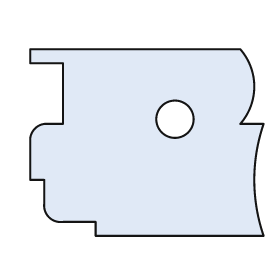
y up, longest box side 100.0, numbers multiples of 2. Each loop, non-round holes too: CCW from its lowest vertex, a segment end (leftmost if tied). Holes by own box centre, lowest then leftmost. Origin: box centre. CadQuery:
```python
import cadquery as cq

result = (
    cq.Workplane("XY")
    .moveTo(-22.0, -40.0)
    .lineTo(50.0, -40.0)
    .threePointArc((46.0, -16.0), (50.0, 8.0))
    .lineTo(40.0, 8.0)
    .threePointArc((46.0, 24.0), (40.0, 40.0))
    .lineTo(-50.0, 40.0)
    .lineTo(-50.0, 34.0)
    .lineTo(-36.0, 34.0)
    .lineTo(-36.0, 8.0)
    .lineTo(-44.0, 8.0)
    .threePointArc((-48.0, 6.0), (-50.0, 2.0))
    .lineTo(-50.0, -16.0)
    .lineTo(-44.0, -16.0)
    .lineTo(-44.0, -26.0)
    .threePointArc((-42.0, -32.0), (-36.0, -34.0))
    .lineTo(-22.0, -34.0)
    .close()
    .moveTo(12.0, 10.0)
    .circle(8.0)
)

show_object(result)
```